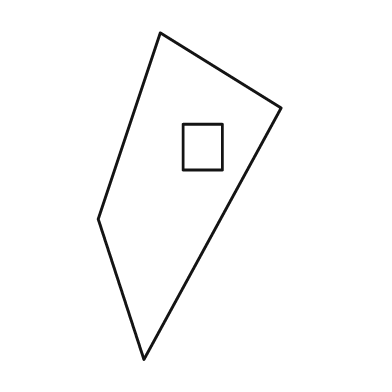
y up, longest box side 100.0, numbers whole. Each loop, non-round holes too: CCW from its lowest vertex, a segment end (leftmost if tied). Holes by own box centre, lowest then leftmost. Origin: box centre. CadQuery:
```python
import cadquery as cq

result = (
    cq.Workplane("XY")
    .moveTo(-14.0, -50.0)
    .lineTo(28.0, 27.0)
    .lineTo(-9.0, 50.0)
    .lineTo(-28.0, -7.0)
    .close()
    .moveTo(-2.0, 8.0)
    .lineTo(10.0, 8.0)
    .lineTo(10.0, 22.0)
    .lineTo(-2.0, 22.0)
    .close()
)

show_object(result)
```